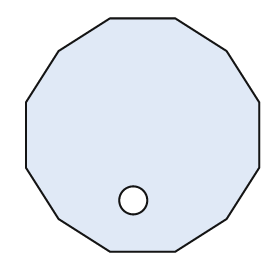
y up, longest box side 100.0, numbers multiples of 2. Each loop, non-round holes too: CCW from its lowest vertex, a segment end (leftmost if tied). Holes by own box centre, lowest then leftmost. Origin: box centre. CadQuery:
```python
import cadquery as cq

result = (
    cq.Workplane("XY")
    .moveTo(-14.0, -50.0)
    .lineTo(14.0, -50.0)
    .lineTo(36.0, -36.0)
    .lineTo(50.0, -14.0)
    .lineTo(50.0, 14.0)
    .lineTo(36.0, 36.0)
    .lineTo(14.0, 50.0)
    .lineTo(-14.0, 50.0)
    .lineTo(-36.0, 36.0)
    .lineTo(-50.0, 14.0)
    .lineTo(-50.0, -14.0)
    .lineTo(-36.0, -36.0)
    .close()
    .moveTo(-4.0, -28.0)
    .circle(6.0)
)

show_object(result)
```